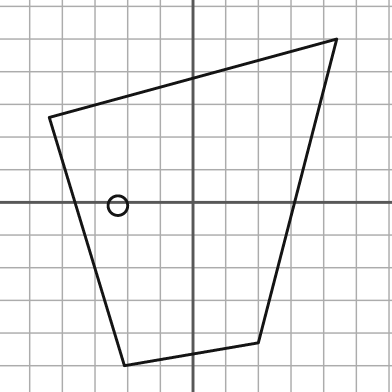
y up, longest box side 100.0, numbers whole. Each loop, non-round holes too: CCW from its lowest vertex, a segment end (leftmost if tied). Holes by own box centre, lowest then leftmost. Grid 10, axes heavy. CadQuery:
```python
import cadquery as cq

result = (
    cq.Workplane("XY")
    .moveTo(-21.0, -50.0)
    .lineTo(20.0, -43.0)
    .lineTo(44.0, 50.0)
    .lineTo(-44.0, 26.0)
    .close()
    .moveTo(-23.0, -1.0)
    .circle(3.0)
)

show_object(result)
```